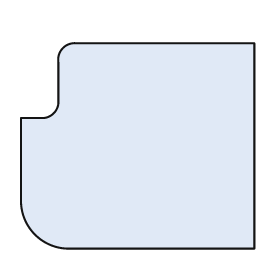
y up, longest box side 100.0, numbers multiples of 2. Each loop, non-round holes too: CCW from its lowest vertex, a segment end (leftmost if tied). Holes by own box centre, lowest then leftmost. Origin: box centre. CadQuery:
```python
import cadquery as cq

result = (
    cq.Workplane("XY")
    .moveTo(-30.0, -44.0)
    .lineTo(50.0, -44.0)
    .lineTo(50.0, 44.0)
    .lineTo(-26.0, 44.0)
    .threePointArc((-32.0, 42.0), (-34.0, 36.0))
    .lineTo(-34.0, 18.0)
    .threePointArc((-36.0, 14.0), (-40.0, 12.0))
    .lineTo(-50.0, 12.0)
    .lineTo(-50.0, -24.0)
    .threePointArc((-44.0, -38.0), (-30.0, -44.0))
    .close()
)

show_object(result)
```